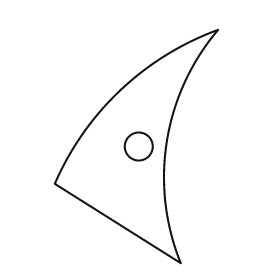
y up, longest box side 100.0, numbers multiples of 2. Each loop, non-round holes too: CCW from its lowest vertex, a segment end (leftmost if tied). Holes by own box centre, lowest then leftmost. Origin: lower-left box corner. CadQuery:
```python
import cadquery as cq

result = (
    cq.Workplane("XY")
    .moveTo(54.0, 0.0)
    .threePointArc((48.0, 52.0), (70.0, 100.0))
    .threePointArc((28.0, 74.0), (0.0, 34.0))
    .close()
    .moveTo(36.0, 50.0)
    .circle(6.0)
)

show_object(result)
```